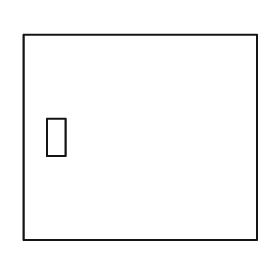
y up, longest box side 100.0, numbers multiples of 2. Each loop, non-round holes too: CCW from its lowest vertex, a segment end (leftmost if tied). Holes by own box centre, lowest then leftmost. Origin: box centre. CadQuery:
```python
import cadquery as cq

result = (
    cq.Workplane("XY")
    .moveTo(-50.0, -44.0)
    .lineTo(50.0, -44.0)
    .lineTo(50.0, 44.0)
    .lineTo(-50.0, 44.0)
    .close()
    .moveTo(-40.0, -8.0)
    .lineTo(-32.0, -8.0)
    .lineTo(-32.0, 8.0)
    .lineTo(-40.0, 8.0)
    .close()
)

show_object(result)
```